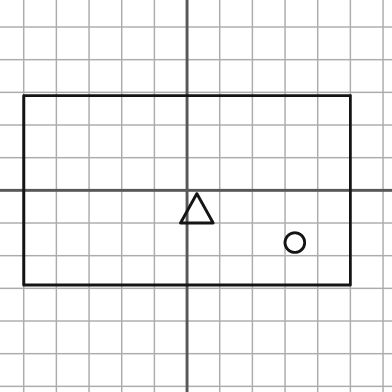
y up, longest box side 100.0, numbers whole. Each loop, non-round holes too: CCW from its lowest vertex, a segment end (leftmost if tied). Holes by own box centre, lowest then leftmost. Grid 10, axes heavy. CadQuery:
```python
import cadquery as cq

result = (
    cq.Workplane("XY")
    .moveTo(-50.0, -29.0)
    .lineTo(50.0, -29.0)
    .lineTo(50.0, 29.0)
    .lineTo(-50.0, 29.0)
    .close()
    .moveTo(33.0, -16.0)
    .circle(3.0)
    .moveTo(-2.0, -10.0)
    .lineTo(8.0, -10.0)
    .lineTo(3.0, -1.0)
    .close()
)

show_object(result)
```